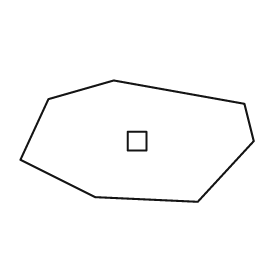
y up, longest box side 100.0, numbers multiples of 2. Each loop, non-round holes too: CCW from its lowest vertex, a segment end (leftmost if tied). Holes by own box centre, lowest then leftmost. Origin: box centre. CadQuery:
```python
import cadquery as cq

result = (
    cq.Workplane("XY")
    .moveTo(26.0, -26.0)
    .lineTo(50.0, 0.0)
    .lineTo(46.0, 16.0)
    .lineTo(-10.0, 26.0)
    .lineTo(-38.0, 18.0)
    .lineTo(-50.0, -8.0)
    .lineTo(-18.0, -24.0)
    .close()
    .moveTo(-4.0, -4.0)
    .lineTo(4.0, -4.0)
    .lineTo(4.0, 4.0)
    .lineTo(-4.0, 4.0)
    .close()
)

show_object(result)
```